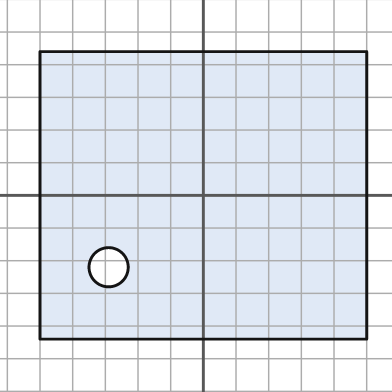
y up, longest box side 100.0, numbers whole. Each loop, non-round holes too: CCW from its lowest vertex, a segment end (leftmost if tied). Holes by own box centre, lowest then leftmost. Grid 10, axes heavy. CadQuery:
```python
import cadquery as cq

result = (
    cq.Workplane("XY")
    .moveTo(-50.0, -44.0)
    .lineTo(50.0, -44.0)
    .lineTo(50.0, 44.0)
    .lineTo(-50.0, 44.0)
    .close()
    .moveTo(-29.0, -22.0)
    .circle(6.0)
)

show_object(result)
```